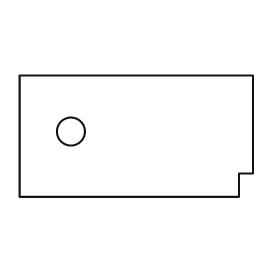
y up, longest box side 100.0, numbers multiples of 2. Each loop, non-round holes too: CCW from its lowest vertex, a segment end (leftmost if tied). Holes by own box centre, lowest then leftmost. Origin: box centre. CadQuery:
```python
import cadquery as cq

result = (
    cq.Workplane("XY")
    .moveTo(-50.0, -26.0)
    .lineTo(44.0, -26.0)
    .lineTo(44.0, -16.0)
    .lineTo(50.0, -16.0)
    .lineTo(50.0, 26.0)
    .lineTo(-50.0, 26.0)
    .close()
    .moveTo(-28.0, 2.0)
    .circle(6.0)
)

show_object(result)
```